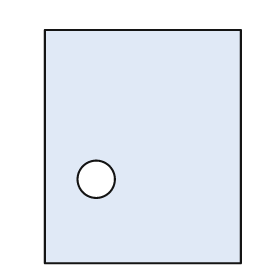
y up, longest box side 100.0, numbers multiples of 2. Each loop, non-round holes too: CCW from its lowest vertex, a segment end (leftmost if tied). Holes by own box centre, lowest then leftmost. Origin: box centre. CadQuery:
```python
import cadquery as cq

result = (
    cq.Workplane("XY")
    .moveTo(-42.0, -50.0)
    .lineTo(42.0, -50.0)
    .lineTo(42.0, 50.0)
    .lineTo(-42.0, 50.0)
    .close()
    .moveTo(-20.0, -14.0)
    .circle(8.0)
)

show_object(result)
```